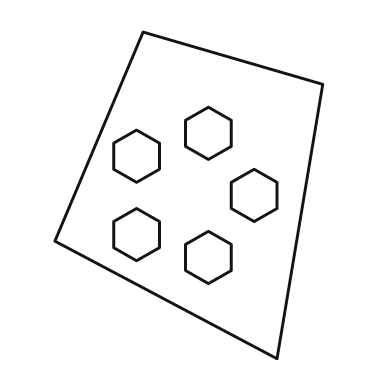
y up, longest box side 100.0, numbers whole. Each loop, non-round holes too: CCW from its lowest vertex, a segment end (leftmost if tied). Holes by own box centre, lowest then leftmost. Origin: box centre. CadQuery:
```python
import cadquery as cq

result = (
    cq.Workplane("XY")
    .moveTo(27.0, -50.0)
    .lineTo(41.0, 34.0)
    .lineTo(-14.0, 50.0)
    .lineTo(-41.0, -14.0)
    .close()
    .moveTo(6.0, -27.0)
    .lineTo(13.0, -23.0)
    .lineTo(13.0, -15.0)
    .lineTo(6.0, -11.0)
    .lineTo(-1.0, -15.0)
    .lineTo(-1.0, -23.0)
    .close()
    .moveTo(-16.0, -20.0)
    .lineTo(-9.0, -16.0)
    .lineTo(-9.0, -8.0)
    .lineTo(-16.0, -4.0)
    .lineTo(-23.0, -8.0)
    .lineTo(-23.0, -16.0)
    .close()
    .moveTo(20.0, -8.0)
    .lineTo(27.0, -4.0)
    .lineTo(27.0, 4.0)
    .lineTo(20.0, 8.0)
    .lineTo(13.0, 4.0)
    .lineTo(13.0, -4.0)
    .close()
    .moveTo(-16.0, 4.0)
    .lineTo(-9.0, 8.0)
    .lineTo(-9.0, 16.0)
    .lineTo(-16.0, 20.0)
    .lineTo(-23.0, 16.0)
    .lineTo(-23.0, 8.0)
    .close()
    .moveTo(6.0, 11.0)
    .lineTo(13.0, 15.0)
    .lineTo(13.0, 23.0)
    .lineTo(6.0, 27.0)
    .lineTo(-1.0, 23.0)
    .lineTo(-1.0, 15.0)
    .close()
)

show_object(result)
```